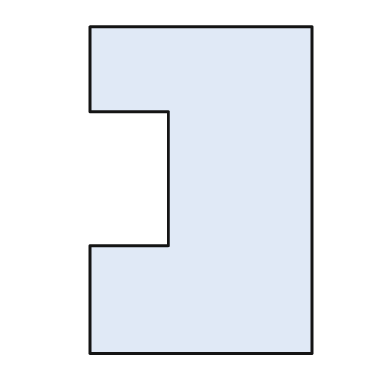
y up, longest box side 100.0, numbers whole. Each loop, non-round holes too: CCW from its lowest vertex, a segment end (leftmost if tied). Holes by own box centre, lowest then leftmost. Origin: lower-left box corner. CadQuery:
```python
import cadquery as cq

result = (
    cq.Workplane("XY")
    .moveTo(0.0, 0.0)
    .lineTo(68.0, 0.0)
    .lineTo(68.0, 100.0)
    .lineTo(0.0, 100.0)
    .lineTo(0.0, 74.0)
    .lineTo(24.0, 74.0)
    .lineTo(24.0, 33.0)
    .lineTo(0.0, 33.0)
    .close()
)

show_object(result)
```